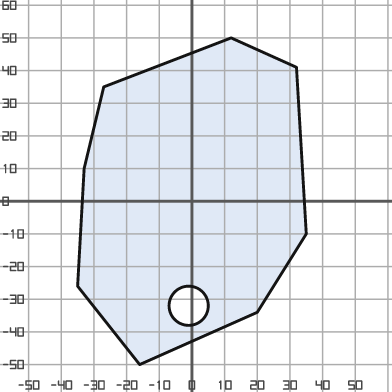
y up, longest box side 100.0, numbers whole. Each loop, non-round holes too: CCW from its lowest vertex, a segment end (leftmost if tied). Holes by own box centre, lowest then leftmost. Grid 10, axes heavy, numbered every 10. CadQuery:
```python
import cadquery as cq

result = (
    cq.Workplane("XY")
    .moveTo(-16.0, -50.0)
    .lineTo(20.0, -34.0)
    .lineTo(35.0, -10.0)
    .lineTo(32.0, 41.0)
    .lineTo(12.0, 50.0)
    .lineTo(-27.0, 35.0)
    .lineTo(-33.0, 10.0)
    .lineTo(-35.0, -26.0)
    .close()
    .moveTo(-1.0, -32.0)
    .circle(6.0)
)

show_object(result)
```